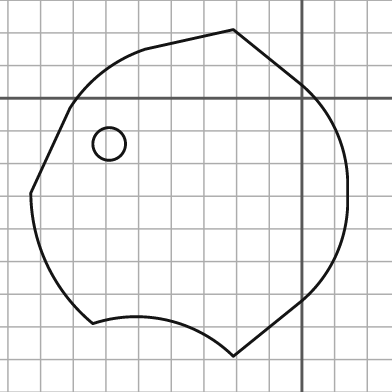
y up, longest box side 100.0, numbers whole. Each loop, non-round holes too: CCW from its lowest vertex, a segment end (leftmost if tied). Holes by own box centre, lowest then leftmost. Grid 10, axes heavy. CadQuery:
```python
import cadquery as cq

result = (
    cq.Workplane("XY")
    .moveTo(-21.0, -79.0)
    .lineTo(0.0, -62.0)
    .threePointArc((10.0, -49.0), (14.0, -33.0))
    .lineTo(14.0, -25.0)
    .threePointArc((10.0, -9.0), (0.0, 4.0))
    .lineTo(-21.0, 21.0)
    .lineTo(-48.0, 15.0)
    .threePointArc((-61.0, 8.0), (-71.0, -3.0))
    .lineTo(-83.0, -29.0)
    .threePointArc((-78.0, -51.0), (-64.0, -69.0))
    .threePointArc((-41.0, -68.0), (-21.0, -79.0))
    .close()
    .moveTo(-59.0, -14.0)
    .circle(5.0)
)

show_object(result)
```